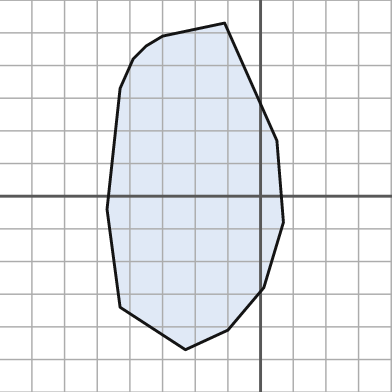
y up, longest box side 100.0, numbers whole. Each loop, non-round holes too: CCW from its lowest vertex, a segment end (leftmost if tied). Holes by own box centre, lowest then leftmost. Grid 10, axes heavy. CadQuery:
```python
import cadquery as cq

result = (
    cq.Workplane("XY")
    .moveTo(-23.0, -47.0)
    .lineTo(-10.0, -41.0)
    .lineTo(1.0, -28.0)
    .lineTo(7.0, -8.0)
    .lineTo(5.0, 17.0)
    .lineTo(-11.0, 53.0)
    .lineTo(-30.0, 49.0)
    .lineTo(-35.0, 46.0)
    .lineTo(-39.0, 42.0)
    .lineTo(-43.0, 33.0)
    .lineTo(-47.0, -4.0)
    .lineTo(-43.0, -34.0)
    .close()
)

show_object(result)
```